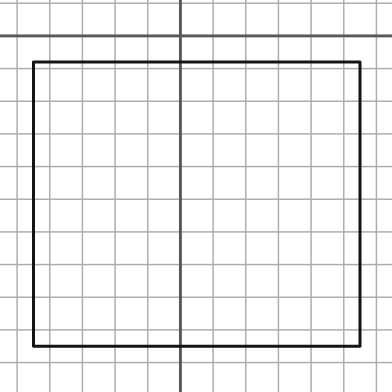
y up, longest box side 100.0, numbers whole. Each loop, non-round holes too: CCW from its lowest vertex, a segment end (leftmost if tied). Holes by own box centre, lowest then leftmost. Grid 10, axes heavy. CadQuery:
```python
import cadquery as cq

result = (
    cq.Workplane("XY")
    .moveTo(-45.0, -95.0)
    .lineTo(55.0, -95.0)
    .lineTo(55.0, -8.0)
    .lineTo(-45.0, -8.0)
    .close()
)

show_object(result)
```